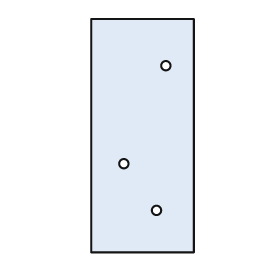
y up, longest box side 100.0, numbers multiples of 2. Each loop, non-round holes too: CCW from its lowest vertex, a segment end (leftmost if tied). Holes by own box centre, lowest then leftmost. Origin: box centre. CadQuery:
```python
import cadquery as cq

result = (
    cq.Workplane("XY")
    .moveTo(-22.0, -50.0)
    .lineTo(22.0, -50.0)
    .lineTo(22.0, 50.0)
    .lineTo(-22.0, 50.0)
    .close()
    .moveTo(6.0, -32.0)
    .circle(2.0)
    .moveTo(-8.0, -12.0)
    .circle(2.0)
    .moveTo(10.0, 30.0)
    .circle(2.0)
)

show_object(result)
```